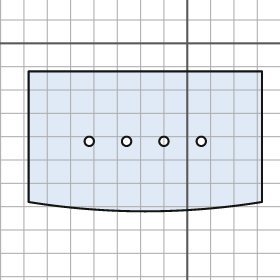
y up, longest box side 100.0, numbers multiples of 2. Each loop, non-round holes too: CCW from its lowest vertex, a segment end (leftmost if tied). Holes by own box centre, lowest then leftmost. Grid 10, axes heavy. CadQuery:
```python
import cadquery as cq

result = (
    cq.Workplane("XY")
    .moveTo(-68.0, -68.0)
    .threePointArc((-18.0, -72.0), (32.0, -68.0))
    .lineTo(32.0, -12.0)
    .lineTo(-68.0, -12.0)
    .close()
    .moveTo(-42.0, -42.0)
    .circle(2.0)
    .moveTo(-26.0, -42.0)
    .circle(2.0)
    .moveTo(-10.0, -42.0)
    .circle(2.0)
    .moveTo(6.0, -42.0)
    .circle(2.0)
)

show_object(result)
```